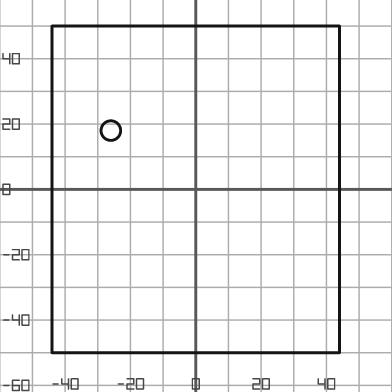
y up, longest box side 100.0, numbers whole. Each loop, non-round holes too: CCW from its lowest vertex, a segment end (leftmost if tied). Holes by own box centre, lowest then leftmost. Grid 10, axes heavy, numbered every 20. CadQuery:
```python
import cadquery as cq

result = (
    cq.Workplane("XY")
    .moveTo(-44.0, -50.0)
    .lineTo(44.0, -50.0)
    .lineTo(44.0, 50.0)
    .lineTo(-44.0, 50.0)
    .close()
    .moveTo(-26.0, 18.0)
    .circle(3.0)
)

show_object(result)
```